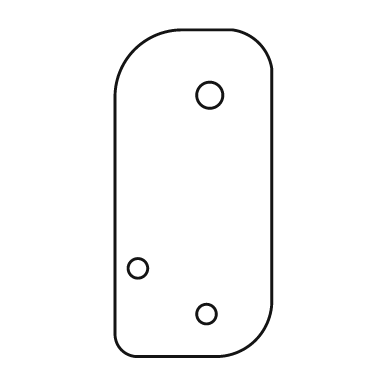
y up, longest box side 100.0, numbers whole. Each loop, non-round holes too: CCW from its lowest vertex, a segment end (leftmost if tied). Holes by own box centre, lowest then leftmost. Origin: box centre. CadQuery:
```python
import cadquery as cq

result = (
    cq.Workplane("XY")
    .moveTo(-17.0, -50.0)
    .lineTo(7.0, -50.0)
    .threePointArc((19.0, -45.0), (24.0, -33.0))
    .lineTo(24.0, 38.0)
    .threePointArc((20.0, 46.0), (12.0, 50.0))
    .lineTo(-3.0, 50.0)
    .threePointArc((-18.0, 44.0), (-24.0, 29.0))
    .lineTo(-24.0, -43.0)
    .threePointArc((-22.0, -48.0), (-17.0, -50.0))
    .close()
    .moveTo(4.0, -37.0)
    .circle(3.0)
    .moveTo(-17.0, -23.0)
    .circle(3.0)
    .moveTo(5.0, 30.0)
    .circle(4.0)
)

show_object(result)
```